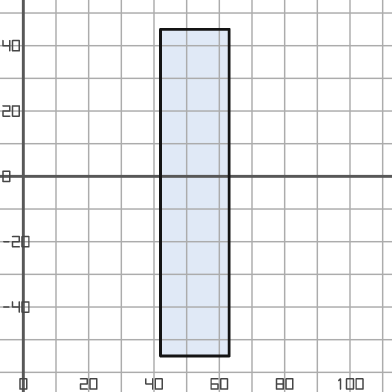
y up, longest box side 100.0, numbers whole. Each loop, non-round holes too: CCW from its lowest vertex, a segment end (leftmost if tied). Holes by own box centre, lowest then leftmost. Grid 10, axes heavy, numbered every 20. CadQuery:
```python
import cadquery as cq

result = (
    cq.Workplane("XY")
    .moveTo(42.0, -55.0)
    .lineTo(63.0, -55.0)
    .lineTo(63.0, 45.0)
    .lineTo(42.0, 45.0)
    .close()
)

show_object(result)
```